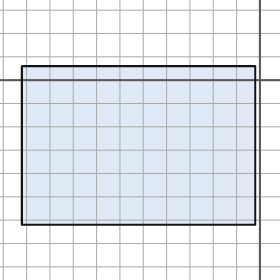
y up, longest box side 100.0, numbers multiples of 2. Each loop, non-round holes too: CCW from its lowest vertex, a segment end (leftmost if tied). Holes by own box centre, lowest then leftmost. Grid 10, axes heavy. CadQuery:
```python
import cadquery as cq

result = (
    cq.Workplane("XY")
    .moveTo(-102.0, -62.0)
    .lineTo(-2.0, -62.0)
    .lineTo(-2.0, 6.0)
    .lineTo(-102.0, 6.0)
    .close()
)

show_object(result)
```